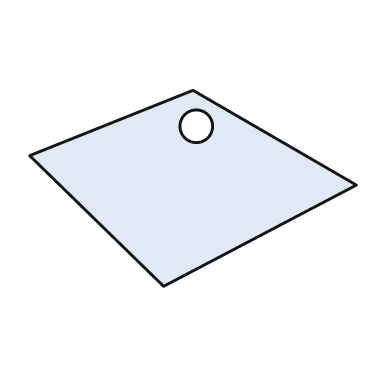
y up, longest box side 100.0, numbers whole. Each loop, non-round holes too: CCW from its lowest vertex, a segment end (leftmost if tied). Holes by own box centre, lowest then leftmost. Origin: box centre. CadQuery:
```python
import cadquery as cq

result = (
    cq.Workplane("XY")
    .moveTo(-9.0, -30.0)
    .lineTo(50.0, 1.0)
    .lineTo(0.0, 30.0)
    .lineTo(-50.0, 10.0)
    .close()
    .moveTo(1.0, 19.0)
    .circle(5.0)
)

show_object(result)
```